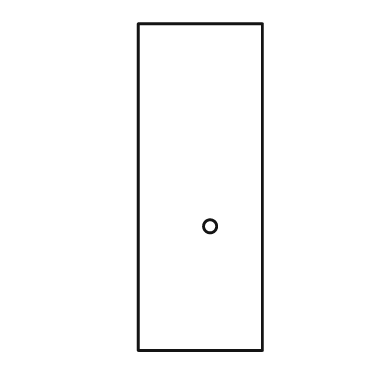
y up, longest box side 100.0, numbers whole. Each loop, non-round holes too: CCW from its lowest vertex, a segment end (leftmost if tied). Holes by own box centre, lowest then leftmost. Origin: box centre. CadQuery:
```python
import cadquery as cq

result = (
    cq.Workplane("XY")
    .moveTo(-19.0, -50.0)
    .lineTo(19.0, -50.0)
    .lineTo(19.0, 50.0)
    .lineTo(-19.0, 50.0)
    .close()
    .moveTo(3.0, -12.0)
    .circle(2.0)
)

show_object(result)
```